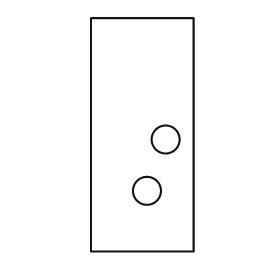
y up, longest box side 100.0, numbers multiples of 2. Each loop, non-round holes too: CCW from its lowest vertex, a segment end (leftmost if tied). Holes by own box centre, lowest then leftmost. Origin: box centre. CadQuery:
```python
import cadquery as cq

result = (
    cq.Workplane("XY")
    .moveTo(-22.0, -50.0)
    .lineTo(22.0, -50.0)
    .lineTo(22.0, 50.0)
    .lineTo(-22.0, 50.0)
    .close()
    .moveTo(2.0, -24.0)
    .circle(6.0)
    .moveTo(10.0, -2.0)
    .circle(6.0)
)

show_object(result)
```